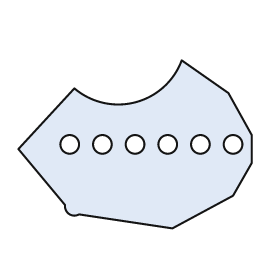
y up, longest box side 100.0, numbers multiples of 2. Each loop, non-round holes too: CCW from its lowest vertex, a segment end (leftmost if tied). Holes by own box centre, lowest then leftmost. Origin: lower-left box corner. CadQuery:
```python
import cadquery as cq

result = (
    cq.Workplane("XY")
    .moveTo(66.0, 0.0)
    .lineTo(92.0, 14.0)
    .lineTo(100.0, 28.0)
    .lineTo(100.0, 40.0)
    .lineTo(90.0, 58.0)
    .lineTo(70.0, 72.0)
    .threePointArc((50.0, 54.0), (24.0, 60.0))
    .lineTo(0.0, 34.0)
    .lineTo(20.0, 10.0)
    .threePointArc((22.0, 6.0), (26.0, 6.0))
    .close()
    .moveTo(22.0, 36.0)
    .circle(4.0)
    .moveTo(36.0, 36.0)
    .circle(4.0)
    .moveTo(50.0, 36.0)
    .circle(4.0)
    .moveTo(64.0, 36.0)
    .circle(4.0)
    .moveTo(78.0, 36.0)
    .circle(4.0)
    .moveTo(92.0, 36.0)
    .circle(4.0)
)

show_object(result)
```